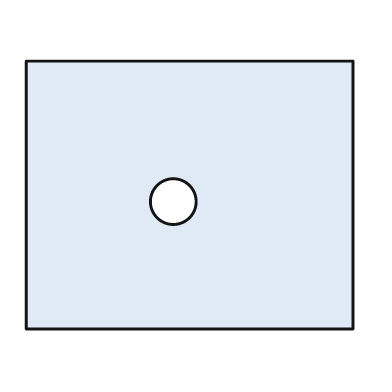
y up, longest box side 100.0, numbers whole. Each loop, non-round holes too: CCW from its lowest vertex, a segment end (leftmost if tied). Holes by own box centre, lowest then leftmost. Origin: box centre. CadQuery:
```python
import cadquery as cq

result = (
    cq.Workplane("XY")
    .moveTo(-50.0, -41.0)
    .lineTo(50.0, -41.0)
    .lineTo(50.0, 41.0)
    .lineTo(-50.0, 41.0)
    .close()
    .moveTo(-5.0, -2.0)
    .circle(7.0)
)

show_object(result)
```